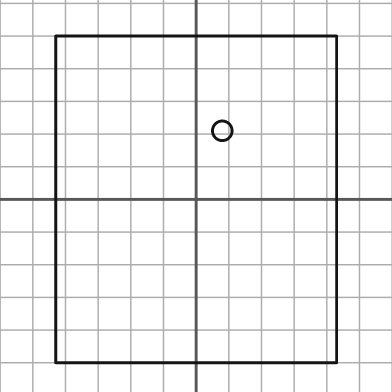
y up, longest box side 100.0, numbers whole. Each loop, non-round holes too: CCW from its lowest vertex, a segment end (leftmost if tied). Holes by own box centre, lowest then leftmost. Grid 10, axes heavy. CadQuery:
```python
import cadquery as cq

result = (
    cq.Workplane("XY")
    .moveTo(-43.0, -50.0)
    .lineTo(43.0, -50.0)
    .lineTo(43.0, 50.0)
    .lineTo(-43.0, 50.0)
    .close()
    .moveTo(8.0, 21.0)
    .circle(3.0)
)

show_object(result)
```